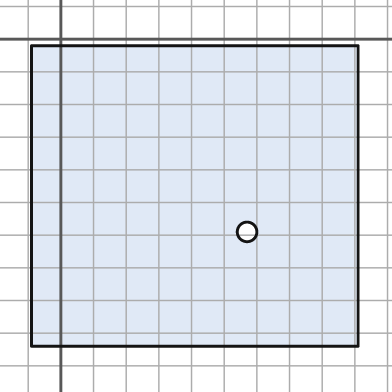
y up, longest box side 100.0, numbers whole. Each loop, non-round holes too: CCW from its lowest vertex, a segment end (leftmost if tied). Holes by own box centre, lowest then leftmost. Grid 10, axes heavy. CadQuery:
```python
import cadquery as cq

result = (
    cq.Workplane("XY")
    .moveTo(-9.0, -94.0)
    .lineTo(91.0, -94.0)
    .lineTo(91.0, -2.0)
    .lineTo(-9.0, -2.0)
    .close()
    .moveTo(57.0, -59.0)
    .circle(3.0)
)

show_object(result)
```